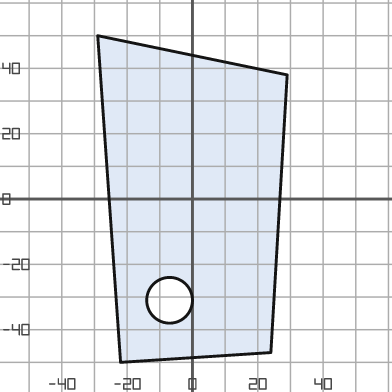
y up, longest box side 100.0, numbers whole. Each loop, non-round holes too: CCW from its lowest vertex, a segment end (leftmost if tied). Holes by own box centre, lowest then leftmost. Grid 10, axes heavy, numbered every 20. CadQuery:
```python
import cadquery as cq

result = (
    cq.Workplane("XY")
    .moveTo(-22.0, -50.0)
    .lineTo(24.0, -47.0)
    .lineTo(29.0, 38.0)
    .lineTo(-29.0, 50.0)
    .close()
    .moveTo(-7.0, -31.0)
    .circle(7.0)
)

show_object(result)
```